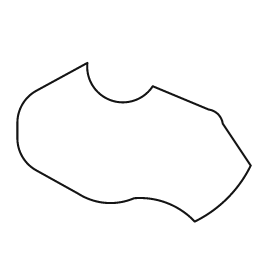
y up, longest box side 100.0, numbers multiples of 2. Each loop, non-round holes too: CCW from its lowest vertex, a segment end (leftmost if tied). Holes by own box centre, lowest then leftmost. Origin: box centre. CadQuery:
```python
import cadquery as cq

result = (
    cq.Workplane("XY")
    .moveTo(26.0, -34.0)
    .threePointArc((40.0, -24.0), (50.0, -10.0))
    .lineTo(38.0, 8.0)
    .threePointArc((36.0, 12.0), (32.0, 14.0))
    .lineTo(8.0, 24.0)
    .threePointArc((-10.0, 18.0), (-20.0, 34.0))
    .lineTo(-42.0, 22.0)
    .threePointArc((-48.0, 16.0), (-50.0, 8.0))
    .lineTo(-50.0, 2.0)
    .threePointArc((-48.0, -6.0), (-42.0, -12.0))
    .lineTo(-24.0, -22.0)
    .threePointArc((-12.0, -26.0), (0.0, -24.0))
    .threePointArc((14.0, -26.0), (26.0, -34.0))
    .close()
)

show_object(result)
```